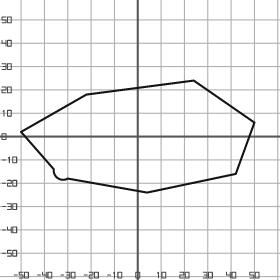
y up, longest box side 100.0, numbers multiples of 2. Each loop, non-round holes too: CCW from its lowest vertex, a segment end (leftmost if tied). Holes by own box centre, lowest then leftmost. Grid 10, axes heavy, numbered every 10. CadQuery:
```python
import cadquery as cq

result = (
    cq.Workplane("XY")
    .moveTo(4.0, -24.0)
    .lineTo(42.0, -16.0)
    .lineTo(50.0, 6.0)
    .lineTo(24.0, 24.0)
    .lineTo(-22.0, 18.0)
    .lineTo(-50.0, 2.0)
    .lineTo(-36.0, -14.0)
    .threePointArc((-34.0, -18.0), (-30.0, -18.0))
    .close()
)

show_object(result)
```